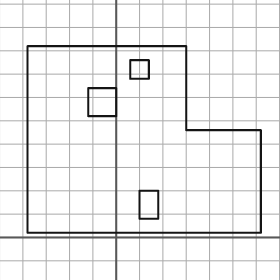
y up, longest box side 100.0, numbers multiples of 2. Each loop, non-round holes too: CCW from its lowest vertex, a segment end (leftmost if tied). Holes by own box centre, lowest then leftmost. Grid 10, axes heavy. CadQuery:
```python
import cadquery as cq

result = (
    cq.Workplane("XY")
    .moveTo(-38.0, 2.0)
    .lineTo(62.0, 2.0)
    .lineTo(62.0, 46.0)
    .lineTo(30.0, 46.0)
    .lineTo(30.0, 82.0)
    .lineTo(-38.0, 82.0)
    .close()
    .moveTo(10.0, 8.0)
    .lineTo(18.0, 8.0)
    .lineTo(18.0, 20.0)
    .lineTo(10.0, 20.0)
    .close()
    .moveTo(-12.0, 52.0)
    .lineTo(0.0, 52.0)
    .lineTo(0.0, 64.0)
    .lineTo(-12.0, 64.0)
    .close()
    .moveTo(6.0, 68.0)
    .lineTo(14.0, 68.0)
    .lineTo(14.0, 76.0)
    .lineTo(6.0, 76.0)
    .close()
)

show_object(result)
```